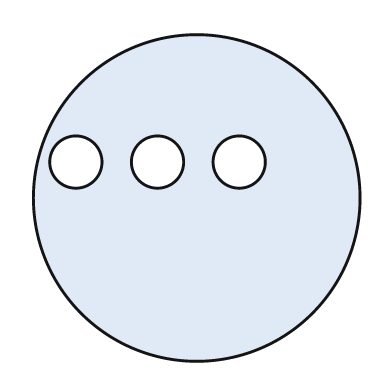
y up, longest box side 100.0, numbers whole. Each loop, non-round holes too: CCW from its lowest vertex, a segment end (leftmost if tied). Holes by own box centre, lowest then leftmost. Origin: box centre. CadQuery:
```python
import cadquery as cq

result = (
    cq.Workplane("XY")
    .moveTo(0.0, 0.0)
    .circle(50.0)
    .moveTo(-37.0, 11.0)
    .circle(8.0)
    .moveTo(-12.0, 11.0)
    .circle(8.0)
    .moveTo(13.0, 11.0)
    .circle(8.0)
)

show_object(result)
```